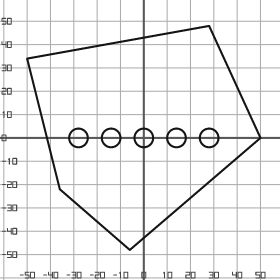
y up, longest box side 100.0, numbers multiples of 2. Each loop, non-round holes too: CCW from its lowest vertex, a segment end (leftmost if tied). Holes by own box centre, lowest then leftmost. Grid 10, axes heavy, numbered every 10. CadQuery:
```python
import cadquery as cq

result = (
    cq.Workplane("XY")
    .moveTo(-6.0, -48.0)
    .lineTo(50.0, 0.0)
    .lineTo(28.0, 48.0)
    .lineTo(-50.0, 34.0)
    .lineTo(-36.0, -22.0)
    .close()
    .moveTo(-28.0, 0.0)
    .circle(4.0)
    .moveTo(-14.0, 0.0)
    .circle(4.0)
    .moveTo(0.0, 0.0)
    .circle(4.0)
    .moveTo(14.0, 0.0)
    .circle(4.0)
    .moveTo(28.0, 0.0)
    .circle(4.0)
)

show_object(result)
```